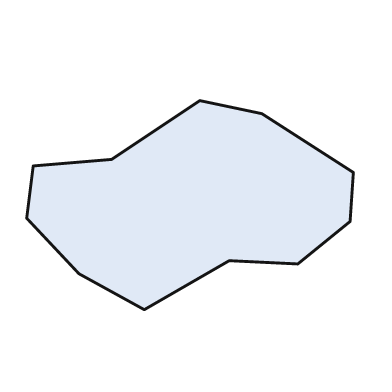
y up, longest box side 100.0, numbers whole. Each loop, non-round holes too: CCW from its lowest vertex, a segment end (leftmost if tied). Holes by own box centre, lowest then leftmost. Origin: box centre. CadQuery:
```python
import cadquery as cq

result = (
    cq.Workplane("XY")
    .moveTo(-14.0, -32.0)
    .lineTo(12.0, -17.0)
    .lineTo(33.0, -18.0)
    .lineTo(49.0, -5.0)
    .lineTo(50.0, 10.0)
    .lineTo(22.0, 28.0)
    .lineTo(3.0, 32.0)
    .lineTo(-24.0, 14.0)
    .lineTo(-48.0, 12.0)
    .lineTo(-50.0, -4.0)
    .lineTo(-34.0, -21.0)
    .close()
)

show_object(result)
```